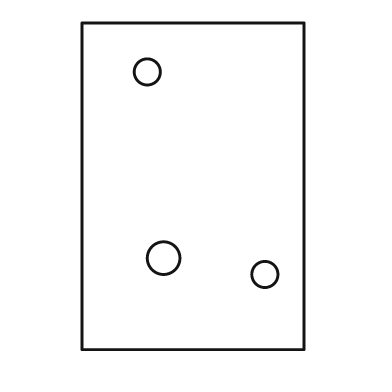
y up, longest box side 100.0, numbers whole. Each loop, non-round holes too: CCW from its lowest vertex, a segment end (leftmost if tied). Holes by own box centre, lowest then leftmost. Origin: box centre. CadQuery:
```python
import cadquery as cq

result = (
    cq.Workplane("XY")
    .moveTo(-34.0, -50.0)
    .lineTo(34.0, -50.0)
    .lineTo(34.0, 50.0)
    .lineTo(-34.0, 50.0)
    .close()
    .moveTo(22.0, -27.0)
    .circle(4.0)
    .moveTo(-9.0, -22.0)
    .circle(5.0)
    .moveTo(-14.0, 35.0)
    .circle(4.0)
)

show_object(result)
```